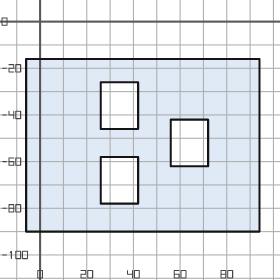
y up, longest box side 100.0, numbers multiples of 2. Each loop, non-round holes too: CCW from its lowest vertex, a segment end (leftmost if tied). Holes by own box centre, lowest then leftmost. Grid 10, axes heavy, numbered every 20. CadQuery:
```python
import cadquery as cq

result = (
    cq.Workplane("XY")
    .moveTo(-6.0, -90.0)
    .lineTo(94.0, -90.0)
    .lineTo(94.0, -16.0)
    .lineTo(-6.0, -16.0)
    .close()
    .moveTo(26.0, -78.0)
    .lineTo(42.0, -78.0)
    .lineTo(42.0, -58.0)
    .lineTo(26.0, -58.0)
    .close()
    .moveTo(56.0, -62.0)
    .lineTo(72.0, -62.0)
    .lineTo(72.0, -42.0)
    .lineTo(56.0, -42.0)
    .close()
    .moveTo(26.0, -46.0)
    .lineTo(42.0, -46.0)
    .lineTo(42.0, -26.0)
    .lineTo(26.0, -26.0)
    .close()
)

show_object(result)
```